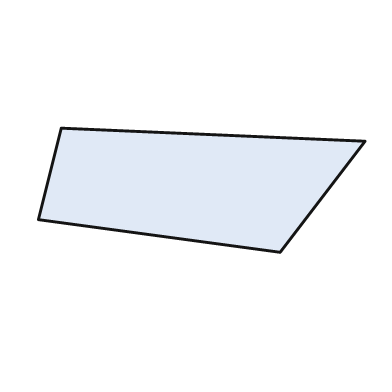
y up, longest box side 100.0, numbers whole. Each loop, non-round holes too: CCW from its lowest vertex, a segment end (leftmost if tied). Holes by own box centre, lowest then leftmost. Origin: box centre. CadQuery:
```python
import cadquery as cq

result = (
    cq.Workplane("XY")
    .moveTo(24.0, -19.0)
    .lineTo(50.0, 15.0)
    .lineTo(-43.0, 19.0)
    .lineTo(-50.0, -9.0)
    .close()
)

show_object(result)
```